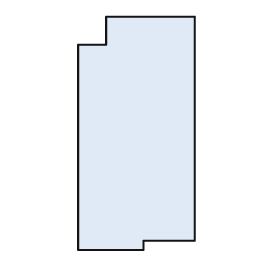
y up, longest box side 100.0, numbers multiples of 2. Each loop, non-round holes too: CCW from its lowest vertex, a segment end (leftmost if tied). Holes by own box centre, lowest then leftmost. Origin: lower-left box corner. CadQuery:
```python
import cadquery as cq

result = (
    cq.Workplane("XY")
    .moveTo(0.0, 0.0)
    .lineTo(28.0, 0.0)
    .lineTo(28.0, 4.0)
    .lineTo(50.0, 4.0)
    .lineTo(50.0, 100.0)
    .lineTo(12.0, 100.0)
    .lineTo(12.0, 88.0)
    .lineTo(0.0, 88.0)
    .close()
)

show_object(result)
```